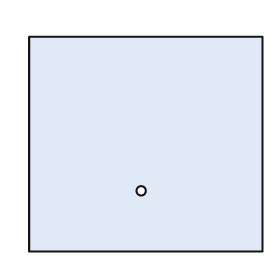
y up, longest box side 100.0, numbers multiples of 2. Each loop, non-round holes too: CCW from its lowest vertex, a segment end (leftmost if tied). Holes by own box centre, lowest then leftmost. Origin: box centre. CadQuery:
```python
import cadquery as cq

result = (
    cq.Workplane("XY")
    .moveTo(-50.0, -46.0)
    .lineTo(50.0, -46.0)
    .lineTo(50.0, 46.0)
    .lineTo(-50.0, 46.0)
    .close()
    .moveTo(-2.0, -20.0)
    .circle(2.0)
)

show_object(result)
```